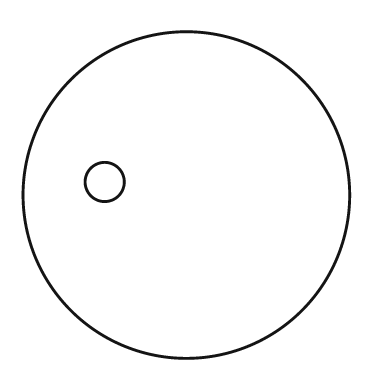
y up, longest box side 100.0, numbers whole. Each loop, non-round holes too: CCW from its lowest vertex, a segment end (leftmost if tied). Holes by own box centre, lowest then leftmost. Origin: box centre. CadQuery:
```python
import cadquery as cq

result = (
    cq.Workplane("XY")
    .moveTo(0.0, 0.0)
    .circle(50.0)
    .moveTo(-25.0, 4.0)
    .circle(6.0)
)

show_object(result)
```